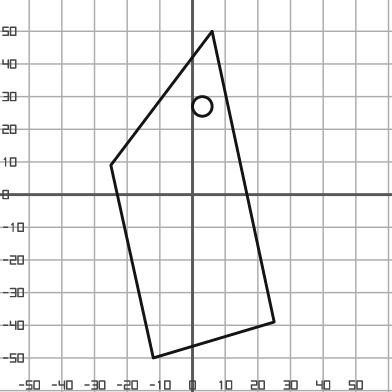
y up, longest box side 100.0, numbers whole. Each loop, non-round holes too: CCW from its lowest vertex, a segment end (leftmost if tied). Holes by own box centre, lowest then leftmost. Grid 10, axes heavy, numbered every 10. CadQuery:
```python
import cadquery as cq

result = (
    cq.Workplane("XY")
    .moveTo(-12.0, -50.0)
    .lineTo(25.0, -39.0)
    .lineTo(6.0, 50.0)
    .lineTo(-25.0, 9.0)
    .close()
    .moveTo(3.0, 27.0)
    .circle(3.0)
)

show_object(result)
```